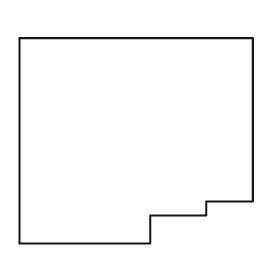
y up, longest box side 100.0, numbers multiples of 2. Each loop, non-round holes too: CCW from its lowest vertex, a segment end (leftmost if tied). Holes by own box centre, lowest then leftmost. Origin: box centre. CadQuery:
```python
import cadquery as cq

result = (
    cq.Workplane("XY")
    .moveTo(-50.0, -44.0)
    .lineTo(6.0, -44.0)
    .lineTo(6.0, -32.0)
    .lineTo(30.0, -32.0)
    .lineTo(30.0, -26.0)
    .lineTo(50.0, -26.0)
    .lineTo(50.0, 44.0)
    .lineTo(-50.0, 44.0)
    .close()
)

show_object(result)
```